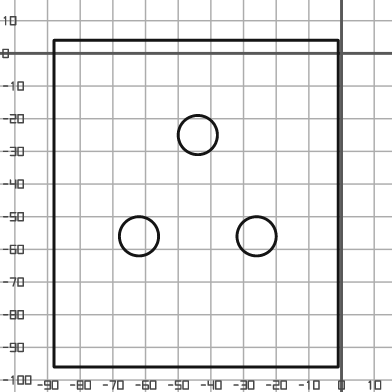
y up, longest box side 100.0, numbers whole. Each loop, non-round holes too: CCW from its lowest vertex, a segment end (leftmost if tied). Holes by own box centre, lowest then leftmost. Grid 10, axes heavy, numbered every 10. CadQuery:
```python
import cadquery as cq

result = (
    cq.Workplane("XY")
    .moveTo(-88.0, -96.0)
    .lineTo(-1.0, -96.0)
    .lineTo(-1.0, 4.0)
    .lineTo(-88.0, 4.0)
    .close()
    .moveTo(-62.0, -56.0)
    .circle(6.0)
    .moveTo(-26.0, -56.0)
    .circle(6.0)
    .moveTo(-44.0, -25.0)
    .circle(6.0)
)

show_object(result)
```